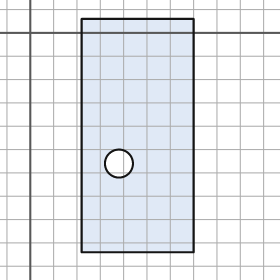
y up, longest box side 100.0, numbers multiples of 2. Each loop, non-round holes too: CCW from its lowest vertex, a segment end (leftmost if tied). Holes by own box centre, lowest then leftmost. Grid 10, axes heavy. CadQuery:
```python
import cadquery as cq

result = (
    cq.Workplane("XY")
    .moveTo(22.0, -94.0)
    .lineTo(70.0, -94.0)
    .lineTo(70.0, 6.0)
    .lineTo(22.0, 6.0)
    .close()
    .moveTo(38.0, -56.0)
    .circle(6.0)
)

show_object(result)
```